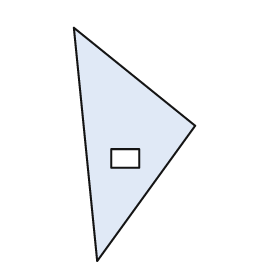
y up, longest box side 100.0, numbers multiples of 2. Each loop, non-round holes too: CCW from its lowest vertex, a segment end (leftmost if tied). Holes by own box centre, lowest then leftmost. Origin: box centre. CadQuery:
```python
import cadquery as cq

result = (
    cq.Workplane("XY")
    .moveTo(-16.0, -50.0)
    .lineTo(26.0, 8.0)
    .lineTo(-26.0, 50.0)
    .close()
    .moveTo(-10.0, -10.0)
    .lineTo(2.0, -10.0)
    .lineTo(2.0, -2.0)
    .lineTo(-10.0, -2.0)
    .close()
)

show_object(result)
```